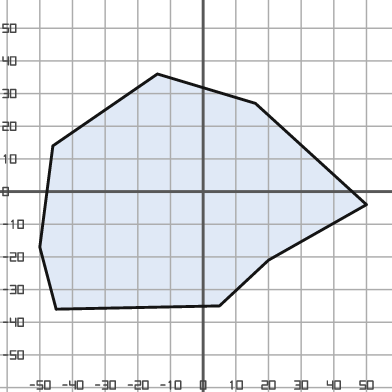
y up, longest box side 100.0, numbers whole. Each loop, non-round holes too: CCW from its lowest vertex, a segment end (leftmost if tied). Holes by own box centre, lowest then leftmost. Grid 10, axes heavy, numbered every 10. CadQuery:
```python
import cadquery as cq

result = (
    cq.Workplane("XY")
    .moveTo(-45.0, -36.0)
    .lineTo(5.0, -35.0)
    .lineTo(20.0, -21.0)
    .lineTo(50.0, -4.0)
    .lineTo(16.0, 27.0)
    .lineTo(-14.0, 36.0)
    .lineTo(-46.0, 14.0)
    .lineTo(-50.0, -17.0)
    .close()
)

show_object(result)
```